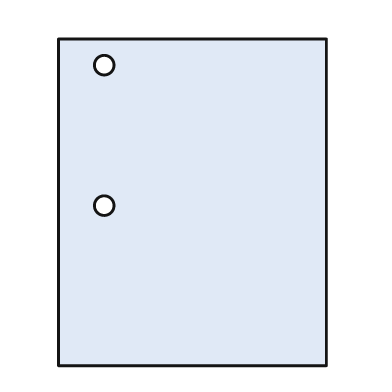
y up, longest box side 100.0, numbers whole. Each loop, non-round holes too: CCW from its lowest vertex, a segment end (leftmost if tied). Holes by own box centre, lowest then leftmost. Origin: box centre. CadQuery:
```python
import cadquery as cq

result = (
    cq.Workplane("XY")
    .moveTo(-41.0, -50.0)
    .lineTo(41.0, -50.0)
    .lineTo(41.0, 50.0)
    .lineTo(-41.0, 50.0)
    .close()
    .moveTo(-27.0, -1.0)
    .circle(3.0)
    .moveTo(-27.0, 42.0)
    .circle(3.0)
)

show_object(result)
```